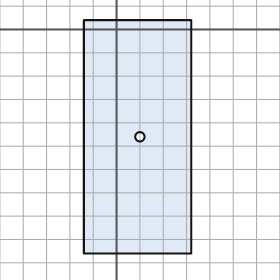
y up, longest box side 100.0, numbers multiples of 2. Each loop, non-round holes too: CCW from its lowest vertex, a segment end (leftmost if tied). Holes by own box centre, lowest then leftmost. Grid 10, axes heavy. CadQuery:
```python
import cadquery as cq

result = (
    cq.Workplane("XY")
    .moveTo(-14.0, -96.0)
    .lineTo(32.0, -96.0)
    .lineTo(32.0, 4.0)
    .lineTo(-14.0, 4.0)
    .close()
    .moveTo(10.0, -46.0)
    .circle(2.0)
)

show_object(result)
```